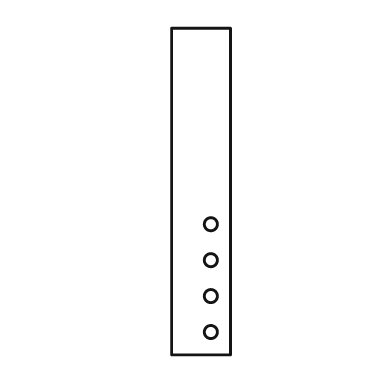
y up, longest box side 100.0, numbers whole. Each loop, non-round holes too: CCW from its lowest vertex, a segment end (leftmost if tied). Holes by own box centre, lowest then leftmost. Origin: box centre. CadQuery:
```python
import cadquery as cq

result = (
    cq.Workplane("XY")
    .moveTo(-9.0, -50.0)
    .lineTo(9.0, -50.0)
    .lineTo(9.0, 50.0)
    .lineTo(-9.0, 50.0)
    .close()
    .moveTo(3.0, -43.0)
    .circle(2.0)
    .moveTo(3.0, -32.0)
    .circle(2.0)
    .moveTo(3.0, -21.0)
    .circle(2.0)
    .moveTo(3.0, -10.0)
    .circle(2.0)
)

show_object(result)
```